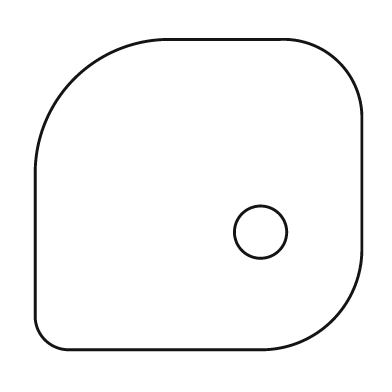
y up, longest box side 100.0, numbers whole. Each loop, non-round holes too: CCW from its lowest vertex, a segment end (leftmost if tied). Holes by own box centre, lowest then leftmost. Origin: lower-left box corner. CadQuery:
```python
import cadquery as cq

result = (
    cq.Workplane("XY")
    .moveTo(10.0, 0.0)
    .lineTo(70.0, 0.0)
    .threePointArc((91.0, 9.0), (100.0, 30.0))
    .lineTo(100.0, 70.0)
    .threePointArc((93.0, 88.0), (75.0, 95.0))
    .lineTo(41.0, 95.0)
    .threePointArc((12.0, 83.0), (0.0, 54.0))
    .lineTo(0.0, 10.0)
    .threePointArc((3.0, 3.0), (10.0, 0.0))
    .close()
    .moveTo(69.0, 36.0)
    .circle(8.0)
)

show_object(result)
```